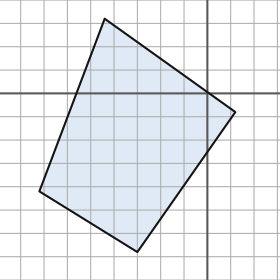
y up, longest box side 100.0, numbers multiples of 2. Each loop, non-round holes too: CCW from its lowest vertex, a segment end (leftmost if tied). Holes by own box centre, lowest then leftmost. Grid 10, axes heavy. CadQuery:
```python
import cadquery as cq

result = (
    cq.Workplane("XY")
    .moveTo(-30.0, -68.0)
    .lineTo(12.0, -8.0)
    .lineTo(-44.0, 32.0)
    .lineTo(-72.0, -42.0)
    .close()
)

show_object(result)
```